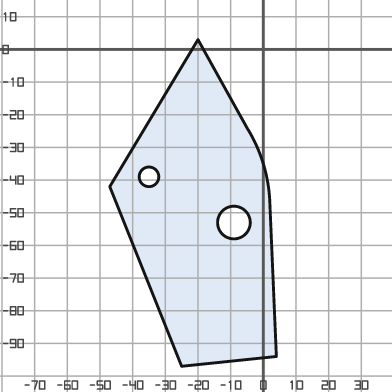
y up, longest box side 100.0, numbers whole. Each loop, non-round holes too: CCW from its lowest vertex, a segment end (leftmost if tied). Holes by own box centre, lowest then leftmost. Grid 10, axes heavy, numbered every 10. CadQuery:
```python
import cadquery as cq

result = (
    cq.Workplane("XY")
    .moveTo(-25.0, -97.0)
    .lineTo(4.0, -94.0)
    .lineTo(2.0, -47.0)
    .threePointArc((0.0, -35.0), (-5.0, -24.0))
    .lineTo(-20.0, 3.0)
    .lineTo(-47.0, -42.0)
    .close()
    .moveTo(-9.0, -53.0)
    .circle(5.0)
    .moveTo(-35.0, -39.0)
    .circle(3.0)
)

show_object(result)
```